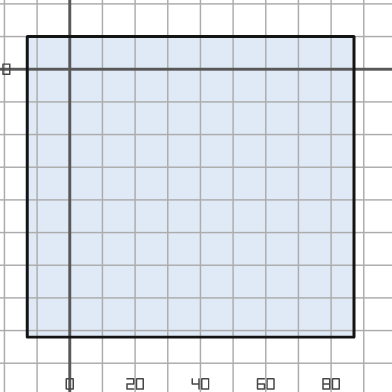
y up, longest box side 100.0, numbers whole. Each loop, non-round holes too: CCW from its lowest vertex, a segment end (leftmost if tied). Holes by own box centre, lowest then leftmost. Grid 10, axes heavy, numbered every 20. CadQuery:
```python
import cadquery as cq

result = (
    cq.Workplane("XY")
    .moveTo(-13.0, -82.0)
    .lineTo(87.0, -82.0)
    .lineTo(87.0, 10.0)
    .lineTo(-13.0, 10.0)
    .close()
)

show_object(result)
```